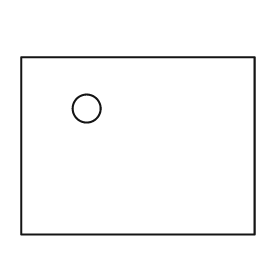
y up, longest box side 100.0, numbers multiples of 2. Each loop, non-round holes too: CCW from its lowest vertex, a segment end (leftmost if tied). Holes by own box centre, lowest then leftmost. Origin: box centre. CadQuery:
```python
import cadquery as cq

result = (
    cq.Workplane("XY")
    .moveTo(-50.0, -38.0)
    .lineTo(50.0, -38.0)
    .lineTo(50.0, 38.0)
    .lineTo(-50.0, 38.0)
    .close()
    .moveTo(-22.0, 16.0)
    .circle(6.0)
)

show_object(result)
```